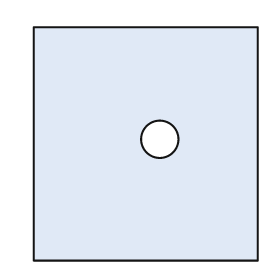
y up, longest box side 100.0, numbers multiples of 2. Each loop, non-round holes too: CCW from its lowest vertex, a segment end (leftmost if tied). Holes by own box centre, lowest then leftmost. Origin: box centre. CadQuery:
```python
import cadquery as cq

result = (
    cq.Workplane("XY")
    .moveTo(-48.0, -50.0)
    .lineTo(48.0, -50.0)
    .lineTo(48.0, 50.0)
    .lineTo(-48.0, 50.0)
    .close()
    .moveTo(6.0, 2.0)
    .circle(8.0)
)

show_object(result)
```